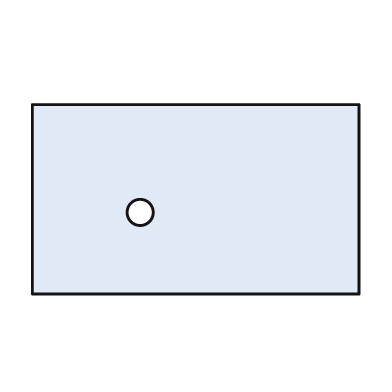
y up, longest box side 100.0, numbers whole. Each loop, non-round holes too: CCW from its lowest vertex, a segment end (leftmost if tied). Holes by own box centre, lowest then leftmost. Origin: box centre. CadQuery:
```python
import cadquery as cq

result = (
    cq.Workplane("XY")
    .moveTo(-50.0, -29.0)
    .lineTo(50.0, -29.0)
    .lineTo(50.0, 29.0)
    .lineTo(-50.0, 29.0)
    .close()
    .moveTo(-17.0, -4.0)
    .circle(4.0)
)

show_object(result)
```